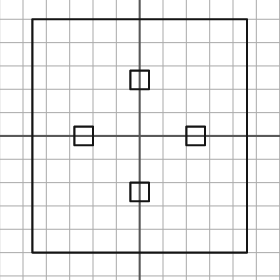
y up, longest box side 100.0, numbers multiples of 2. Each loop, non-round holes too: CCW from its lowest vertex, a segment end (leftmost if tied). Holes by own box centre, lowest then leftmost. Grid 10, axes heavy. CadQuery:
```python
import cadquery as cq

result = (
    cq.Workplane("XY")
    .moveTo(-46.0, -50.0)
    .lineTo(46.0, -50.0)
    .lineTo(46.0, 50.0)
    .lineTo(-46.0, 50.0)
    .close()
    .moveTo(-4.0, -28.0)
    .lineTo(4.0, -28.0)
    .lineTo(4.0, -20.0)
    .lineTo(-4.0, -20.0)
    .close()
    .moveTo(-28.0, -4.0)
    .lineTo(-20.0, -4.0)
    .lineTo(-20.0, 4.0)
    .lineTo(-28.0, 4.0)
    .close()
    .moveTo(20.0, -4.0)
    .lineTo(28.0, -4.0)
    .lineTo(28.0, 4.0)
    .lineTo(20.0, 4.0)
    .close()
    .moveTo(-4.0, 20.0)
    .lineTo(4.0, 20.0)
    .lineTo(4.0, 28.0)
    .lineTo(-4.0, 28.0)
    .close()
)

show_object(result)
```